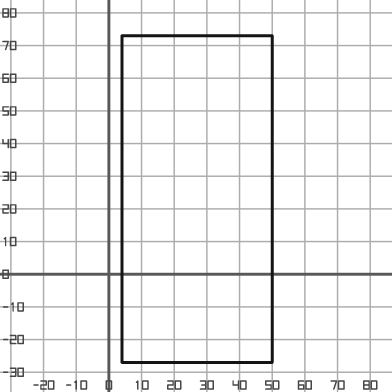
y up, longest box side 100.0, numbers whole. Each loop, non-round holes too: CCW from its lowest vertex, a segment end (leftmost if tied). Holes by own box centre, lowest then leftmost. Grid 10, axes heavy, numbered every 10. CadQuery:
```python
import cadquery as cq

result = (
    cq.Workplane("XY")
    .moveTo(4.0, -27.0)
    .lineTo(50.0, -27.0)
    .lineTo(50.0, 73.0)
    .lineTo(4.0, 73.0)
    .close()
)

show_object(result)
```